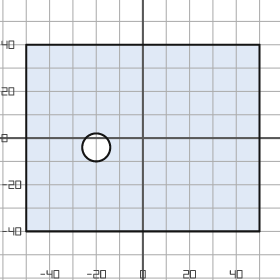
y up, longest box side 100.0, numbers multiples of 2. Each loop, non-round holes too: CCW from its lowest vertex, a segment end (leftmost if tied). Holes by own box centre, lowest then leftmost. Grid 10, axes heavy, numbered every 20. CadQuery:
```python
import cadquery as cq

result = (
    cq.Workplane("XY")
    .moveTo(-50.0, -40.0)
    .lineTo(50.0, -40.0)
    .lineTo(50.0, 40.0)
    .lineTo(-50.0, 40.0)
    .close()
    .moveTo(-20.0, -4.0)
    .circle(6.0)
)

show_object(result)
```